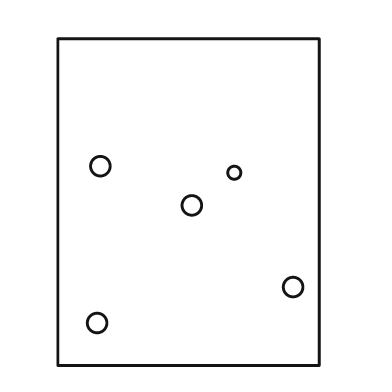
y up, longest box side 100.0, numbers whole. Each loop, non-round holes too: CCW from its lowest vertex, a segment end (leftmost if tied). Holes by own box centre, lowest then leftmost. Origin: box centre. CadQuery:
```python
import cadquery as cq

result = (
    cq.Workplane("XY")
    .moveTo(-40.0, -50.0)
    .lineTo(40.0, -50.0)
    .lineTo(40.0, 50.0)
    .lineTo(-40.0, 50.0)
    .close()
    .moveTo(-28.0, -37.0)
    .circle(3.0)
    .moveTo(32.0, -26.0)
    .circle(3.0)
    .moveTo(1.0, -1.0)
    .circle(3.0)
    .moveTo(14.0, 9.0)
    .circle(2.0)
    .moveTo(-27.0, 11.0)
    .circle(3.0)
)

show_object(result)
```